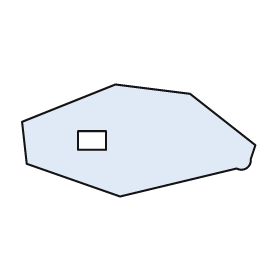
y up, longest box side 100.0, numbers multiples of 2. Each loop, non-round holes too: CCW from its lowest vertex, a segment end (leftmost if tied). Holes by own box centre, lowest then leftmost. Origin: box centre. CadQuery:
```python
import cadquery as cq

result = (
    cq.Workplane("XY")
    .moveTo(-8.0, -24.0)
    .lineTo(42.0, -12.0)
    .threePointArc((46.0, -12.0), (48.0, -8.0))
    .lineTo(50.0, -2.0)
    .lineTo(22.0, 20.0)
    .lineTo(-10.0, 24.0)
    .lineTo(-50.0, 8.0)
    .lineTo(-48.0, -10.0)
    .close()
    .moveTo(-26.0, -4.0)
    .lineTo(-14.0, -4.0)
    .lineTo(-14.0, 4.0)
    .lineTo(-26.0, 4.0)
    .close()
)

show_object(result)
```